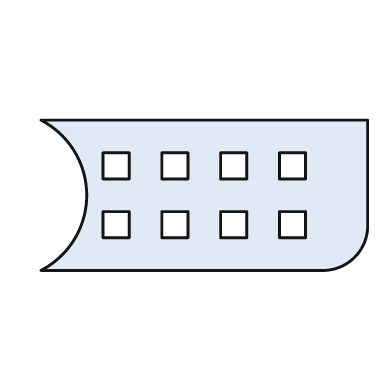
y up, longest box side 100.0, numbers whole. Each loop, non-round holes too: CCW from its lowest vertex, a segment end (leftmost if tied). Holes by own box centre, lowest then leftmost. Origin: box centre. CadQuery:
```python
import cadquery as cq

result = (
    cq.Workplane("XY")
    .moveTo(-50.0, -23.0)
    .lineTo(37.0, -23.0)
    .threePointArc((46.0, -19.0), (50.0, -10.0))
    .lineTo(50.0, 23.0)
    .lineTo(-50.0, 23.0)
    .threePointArc((-36.0, 0.0), (-50.0, -23.0))
    .close()
    .moveTo(-31.0, -13.0)
    .lineTo(-23.0, -13.0)
    .lineTo(-23.0, -5.0)
    .lineTo(-31.0, -5.0)
    .close()
    .moveTo(-13.0, -13.0)
    .lineTo(-5.0, -13.0)
    .lineTo(-5.0, -5.0)
    .lineTo(-13.0, -5.0)
    .close()
    .moveTo(5.0, -13.0)
    .lineTo(13.0, -13.0)
    .lineTo(13.0, -5.0)
    .lineTo(5.0, -5.0)
    .close()
    .moveTo(23.0, -13.0)
    .lineTo(31.0, -13.0)
    .lineTo(31.0, -5.0)
    .lineTo(23.0, -5.0)
    .close()
    .moveTo(-31.0, 5.0)
    .lineTo(-23.0, 5.0)
    .lineTo(-23.0, 13.0)
    .lineTo(-31.0, 13.0)
    .close()
    .moveTo(-13.0, 5.0)
    .lineTo(-5.0, 5.0)
    .lineTo(-5.0, 13.0)
    .lineTo(-13.0, 13.0)
    .close()
    .moveTo(5.0, 5.0)
    .lineTo(13.0, 5.0)
    .lineTo(13.0, 13.0)
    .lineTo(5.0, 13.0)
    .close()
    .moveTo(23.0, 5.0)
    .lineTo(31.0, 5.0)
    .lineTo(31.0, 13.0)
    .lineTo(23.0, 13.0)
    .close()
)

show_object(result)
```